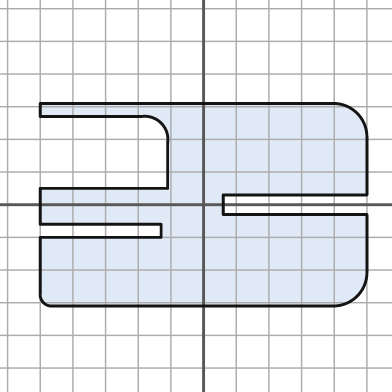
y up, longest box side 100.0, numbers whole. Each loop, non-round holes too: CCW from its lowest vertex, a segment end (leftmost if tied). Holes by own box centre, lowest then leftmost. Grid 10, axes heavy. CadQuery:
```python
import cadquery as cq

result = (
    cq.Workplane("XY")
    .moveTo(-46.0, -31.0)
    .lineTo(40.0, -31.0)
    .threePointArc((47.0, -28.0), (50.0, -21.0))
    .lineTo(50.0, -3.0)
    .lineTo(6.0, -3.0)
    .lineTo(6.0, 3.0)
    .lineTo(50.0, 3.0)
    .lineTo(50.0, 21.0)
    .threePointArc((47.0, 28.0), (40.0, 31.0))
    .lineTo(-50.0, 31.0)
    .lineTo(-50.0, 27.0)
    .lineTo(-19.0, 27.0)
    .threePointArc((-13.0, 25.0), (-11.0, 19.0))
    .lineTo(-11.0, 5.0)
    .lineTo(-50.0, 5.0)
    .lineTo(-50.0, -6.0)
    .lineTo(-13.0, -6.0)
    .lineTo(-13.0, -10.0)
    .lineTo(-50.0, -10.0)
    .lineTo(-50.0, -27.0)
    .threePointArc((-49.0, -30.0), (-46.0, -31.0))
    .close()
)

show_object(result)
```